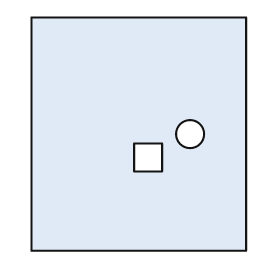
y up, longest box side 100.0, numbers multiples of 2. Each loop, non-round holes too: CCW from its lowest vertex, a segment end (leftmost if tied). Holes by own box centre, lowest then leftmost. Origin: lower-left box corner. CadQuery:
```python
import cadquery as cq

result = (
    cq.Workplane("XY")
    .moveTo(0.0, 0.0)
    .lineTo(92.0, 0.0)
    .lineTo(92.0, 100.0)
    .lineTo(0.0, 100.0)
    .close()
    .moveTo(44.0, 34.0)
    .lineTo(56.0, 34.0)
    .lineTo(56.0, 46.0)
    .lineTo(44.0, 46.0)
    .close()
    .moveTo(68.0, 50.0)
    .circle(6.0)
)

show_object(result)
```